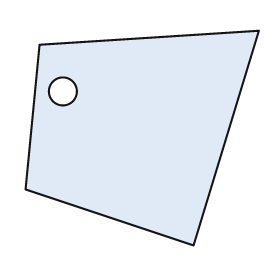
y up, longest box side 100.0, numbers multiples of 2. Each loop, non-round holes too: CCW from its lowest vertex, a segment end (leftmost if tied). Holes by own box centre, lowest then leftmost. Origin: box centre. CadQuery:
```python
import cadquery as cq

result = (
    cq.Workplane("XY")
    .moveTo(22.0, -46.0)
    .lineTo(50.0, 46.0)
    .lineTo(-44.0, 40.0)
    .lineTo(-50.0, -22.0)
    .close()
    .moveTo(-34.0, 20.0)
    .circle(6.0)
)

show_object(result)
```